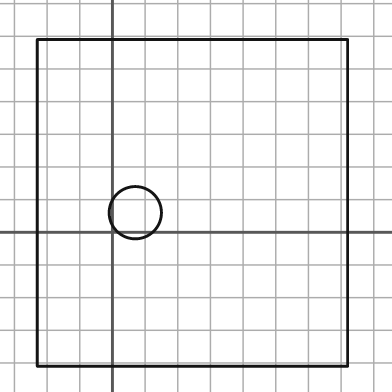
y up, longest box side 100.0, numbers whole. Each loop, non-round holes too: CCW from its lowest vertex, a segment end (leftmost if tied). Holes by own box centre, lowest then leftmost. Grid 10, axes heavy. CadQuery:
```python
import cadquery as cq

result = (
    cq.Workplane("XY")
    .moveTo(-23.0, -41.0)
    .lineTo(72.0, -41.0)
    .lineTo(72.0, 59.0)
    .lineTo(-23.0, 59.0)
    .close()
    .moveTo(7.0, 6.0)
    .circle(8.0)
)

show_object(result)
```